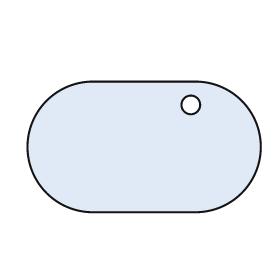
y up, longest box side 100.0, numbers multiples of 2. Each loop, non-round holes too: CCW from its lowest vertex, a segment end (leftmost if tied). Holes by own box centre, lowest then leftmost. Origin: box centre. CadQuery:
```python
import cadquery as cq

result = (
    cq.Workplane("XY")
    .moveTo(-22.0, -28.0)
    .lineTo(22.0, -28.0)
    .threePointArc((50.0, 0.0), (22.0, 28.0))
    .lineTo(-22.0, 28.0)
    .threePointArc((-50.0, 0.0), (-22.0, -28.0))
    .close()
    .moveTo(20.0, 18.0)
    .circle(4.0)
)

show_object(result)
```